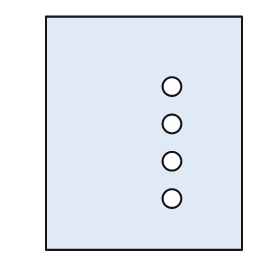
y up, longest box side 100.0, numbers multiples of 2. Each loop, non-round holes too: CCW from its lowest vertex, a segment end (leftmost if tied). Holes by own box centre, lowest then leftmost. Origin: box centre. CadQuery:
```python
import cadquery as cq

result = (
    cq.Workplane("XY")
    .moveTo(-42.0, -50.0)
    .lineTo(42.0, -50.0)
    .lineTo(42.0, 50.0)
    .lineTo(-42.0, 50.0)
    .close()
    .moveTo(12.0, -28.0)
    .circle(4.0)
    .moveTo(12.0, -12.0)
    .circle(4.0)
    .moveTo(12.0, 4.0)
    .circle(4.0)
    .moveTo(12.0, 20.0)
    .circle(4.0)
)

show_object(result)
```